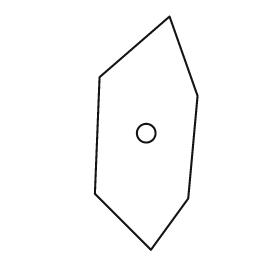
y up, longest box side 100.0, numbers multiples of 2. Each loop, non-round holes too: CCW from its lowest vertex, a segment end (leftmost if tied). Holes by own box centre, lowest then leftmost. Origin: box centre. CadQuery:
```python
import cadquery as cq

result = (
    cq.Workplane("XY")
    .moveTo(2.0, -50.0)
    .lineTo(18.0, -28.0)
    .lineTo(22.0, 16.0)
    .lineTo(10.0, 50.0)
    .lineTo(-20.0, 24.0)
    .lineTo(-22.0, -26.0)
    .close()
    .moveTo(0.0, 0.0)
    .circle(4.0)
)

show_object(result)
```